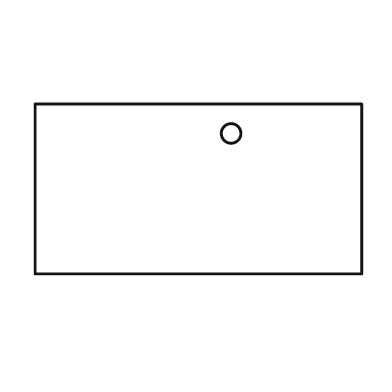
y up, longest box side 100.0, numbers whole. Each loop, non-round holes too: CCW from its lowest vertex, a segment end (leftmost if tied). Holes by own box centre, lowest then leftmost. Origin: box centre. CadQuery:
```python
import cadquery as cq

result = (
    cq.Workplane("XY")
    .moveTo(-50.0, -26.0)
    .lineTo(50.0, -26.0)
    .lineTo(50.0, 26.0)
    .lineTo(-50.0, 26.0)
    .close()
    .moveTo(10.0, 17.0)
    .circle(3.0)
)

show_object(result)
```